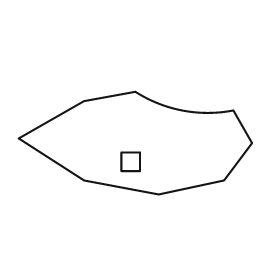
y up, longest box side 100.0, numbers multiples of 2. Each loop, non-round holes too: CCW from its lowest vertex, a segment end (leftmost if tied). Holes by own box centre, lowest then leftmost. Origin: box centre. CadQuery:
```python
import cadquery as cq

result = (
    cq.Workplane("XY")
    .moveTo(10.0, -22.0)
    .lineTo(38.0, -16.0)
    .lineTo(50.0, 0.0)
    .lineTo(42.0, 14.0)
    .threePointArc((20.0, 14.0), (0.0, 22.0))
    .lineTo(-22.0, 18.0)
    .lineTo(-50.0, 2.0)
    .lineTo(-22.0, -16.0)
    .close()
    .moveTo(-6.0, -12.0)
    .lineTo(2.0, -12.0)
    .lineTo(2.0, -4.0)
    .lineTo(-6.0, -4.0)
    .close()
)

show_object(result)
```